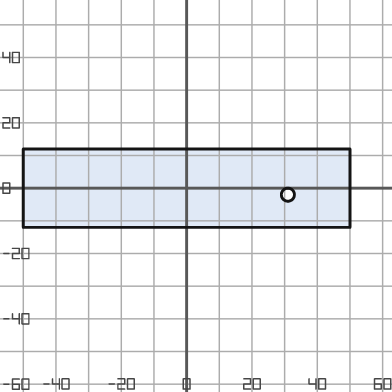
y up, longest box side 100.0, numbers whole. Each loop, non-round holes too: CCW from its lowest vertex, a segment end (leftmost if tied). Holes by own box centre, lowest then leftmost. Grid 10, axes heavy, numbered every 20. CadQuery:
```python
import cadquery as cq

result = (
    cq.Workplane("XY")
    .moveTo(-50.0, -12.0)
    .lineTo(50.0, -12.0)
    .lineTo(50.0, 12.0)
    .lineTo(-50.0, 12.0)
    .close()
    .moveTo(31.0, -2.0)
    .circle(2.0)
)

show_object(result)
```